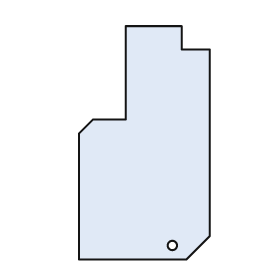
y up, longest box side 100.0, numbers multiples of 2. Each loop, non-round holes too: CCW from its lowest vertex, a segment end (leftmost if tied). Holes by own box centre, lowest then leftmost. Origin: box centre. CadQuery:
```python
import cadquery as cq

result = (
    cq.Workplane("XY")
    .moveTo(-28.0, -50.0)
    .lineTo(18.0, -50.0)
    .lineTo(28.0, -40.0)
    .lineTo(28.0, 40.0)
    .lineTo(16.0, 40.0)
    .lineTo(16.0, 50.0)
    .lineTo(-8.0, 50.0)
    .lineTo(-8.0, 10.0)
    .lineTo(-22.0, 10.0)
    .lineTo(-28.0, 4.0)
    .close()
    .moveTo(12.0, -44.0)
    .circle(2.0)
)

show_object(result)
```